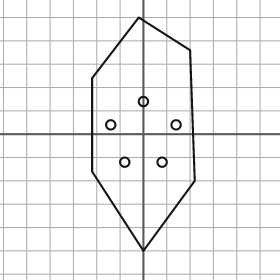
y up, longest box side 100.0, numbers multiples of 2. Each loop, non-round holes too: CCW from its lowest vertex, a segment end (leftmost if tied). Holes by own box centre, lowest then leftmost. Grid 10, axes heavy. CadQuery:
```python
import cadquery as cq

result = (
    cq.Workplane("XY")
    .moveTo(0.0, -50.0)
    .lineTo(22.0, -20.0)
    .lineTo(20.0, 36.0)
    .lineTo(-2.0, 50.0)
    .lineTo(-22.0, 24.0)
    .lineTo(-22.0, -16.0)
    .close()
    .moveTo(-8.0, -12.0)
    .circle(2.0)
    .moveTo(8.0, -12.0)
    .circle(2.0)
    .moveTo(-14.0, 4.0)
    .circle(2.0)
    .moveTo(14.0, 4.0)
    .circle(2.0)
    .moveTo(0.0, 14.0)
    .circle(2.0)
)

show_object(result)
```